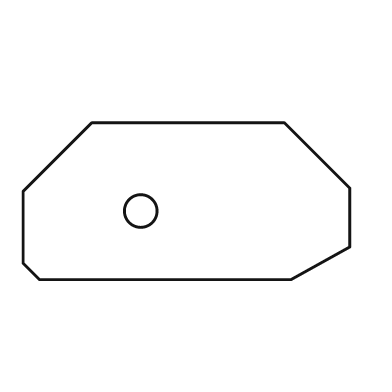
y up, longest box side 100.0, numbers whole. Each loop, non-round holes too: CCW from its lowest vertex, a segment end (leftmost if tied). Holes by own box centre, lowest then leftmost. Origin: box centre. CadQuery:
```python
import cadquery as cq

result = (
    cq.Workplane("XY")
    .moveTo(-45.0, -24.0)
    .lineTo(32.0, -24.0)
    .lineTo(50.0, -14.0)
    .lineTo(50.0, 4.0)
    .lineTo(30.0, 24.0)
    .lineTo(-29.0, 24.0)
    .lineTo(-50.0, 3.0)
    .lineTo(-50.0, -19.0)
    .close()
    .moveTo(-14.0, -3.0)
    .circle(5.0)
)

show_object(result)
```